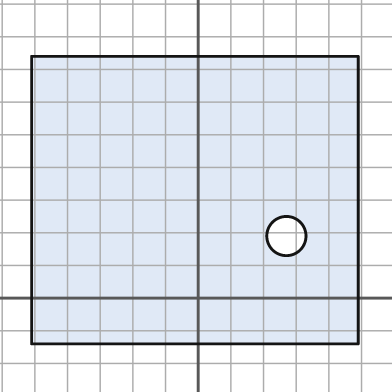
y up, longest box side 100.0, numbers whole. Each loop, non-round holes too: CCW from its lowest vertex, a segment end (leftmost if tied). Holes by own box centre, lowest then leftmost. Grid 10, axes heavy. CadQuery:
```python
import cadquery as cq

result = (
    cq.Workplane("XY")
    .moveTo(-51.0, -14.0)
    .lineTo(49.0, -14.0)
    .lineTo(49.0, 74.0)
    .lineTo(-51.0, 74.0)
    .close()
    .moveTo(27.0, 19.0)
    .circle(6.0)
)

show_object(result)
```